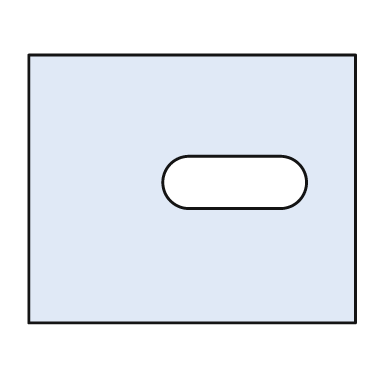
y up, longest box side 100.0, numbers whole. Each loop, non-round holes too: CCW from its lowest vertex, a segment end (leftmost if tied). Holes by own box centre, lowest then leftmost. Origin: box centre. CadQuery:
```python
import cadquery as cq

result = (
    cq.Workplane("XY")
    .moveTo(-50.0, -41.0)
    .lineTo(50.0, -41.0)
    .lineTo(50.0, 41.0)
    .lineTo(-50.0, 41.0)
    .close()
    .moveTo(-1.0, -6.0)
    .lineTo(27.0, -6.0)
    .threePointArc((35.0, 2.0), (27.0, 10.0))
    .lineTo(-1.0, 10.0)
    .threePointArc((-9.0, 2.0), (-1.0, -6.0))
    .close()
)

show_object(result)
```